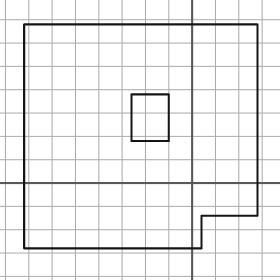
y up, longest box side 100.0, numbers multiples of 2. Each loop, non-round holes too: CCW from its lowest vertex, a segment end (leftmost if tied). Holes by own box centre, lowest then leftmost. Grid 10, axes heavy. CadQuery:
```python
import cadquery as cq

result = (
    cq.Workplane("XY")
    .moveTo(-72.0, -28.0)
    .lineTo(4.0, -28.0)
    .lineTo(4.0, -14.0)
    .lineTo(28.0, -14.0)
    .lineTo(28.0, 68.0)
    .lineTo(-72.0, 68.0)
    .close()
    .moveTo(-26.0, 18.0)
    .lineTo(-10.0, 18.0)
    .lineTo(-10.0, 38.0)
    .lineTo(-26.0, 38.0)
    .close()
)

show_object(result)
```